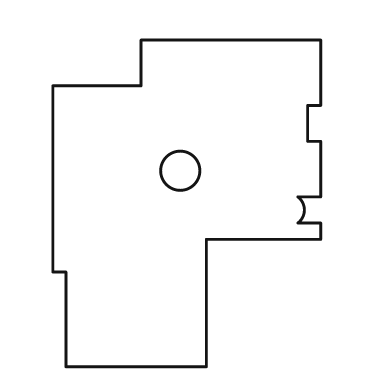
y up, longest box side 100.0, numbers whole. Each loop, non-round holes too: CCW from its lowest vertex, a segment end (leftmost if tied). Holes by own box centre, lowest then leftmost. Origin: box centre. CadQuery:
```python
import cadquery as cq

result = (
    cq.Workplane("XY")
    .moveTo(-37.0, -50.0)
    .lineTo(6.0, -50.0)
    .lineTo(6.0, -11.0)
    .lineTo(41.0, -11.0)
    .lineTo(41.0, -6.0)
    .lineTo(34.0, -6.0)
    .threePointArc((36.0, -2.0), (34.0, 2.0))
    .lineTo(41.0, 2.0)
    .lineTo(41.0, 19.0)
    .lineTo(37.0, 19.0)
    .lineTo(37.0, 30.0)
    .lineTo(41.0, 30.0)
    .lineTo(41.0, 50.0)
    .lineTo(-14.0, 50.0)
    .lineTo(-14.0, 36.0)
    .lineTo(-41.0, 36.0)
    .lineTo(-41.0, -21.0)
    .lineTo(-37.0, -21.0)
    .close()
    .moveTo(-2.0, 10.0)
    .circle(6.0)
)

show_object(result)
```